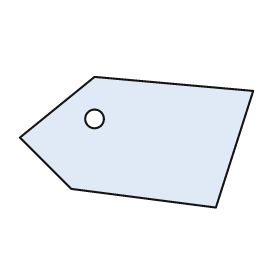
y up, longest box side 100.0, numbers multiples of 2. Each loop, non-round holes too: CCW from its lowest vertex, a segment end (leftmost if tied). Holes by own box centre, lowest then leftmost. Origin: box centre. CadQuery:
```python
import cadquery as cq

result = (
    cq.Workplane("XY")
    .moveTo(34.0, -28.0)
    .lineTo(50.0, 22.0)
    .lineTo(-18.0, 28.0)
    .lineTo(-50.0, 2.0)
    .lineTo(-28.0, -20.0)
    .close()
    .moveTo(-18.0, 10.0)
    .circle(4.0)
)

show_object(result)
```